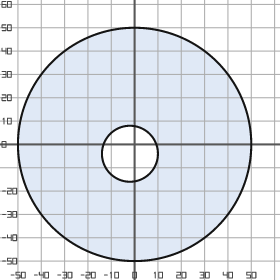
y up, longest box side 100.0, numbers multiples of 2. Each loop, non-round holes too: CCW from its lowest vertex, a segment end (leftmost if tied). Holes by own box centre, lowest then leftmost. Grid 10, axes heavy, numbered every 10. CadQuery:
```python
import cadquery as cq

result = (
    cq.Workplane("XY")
    .moveTo(0.0, 0.0)
    .circle(50.0)
    .moveTo(-2.0, -4.0)
    .circle(12.0)
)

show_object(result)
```